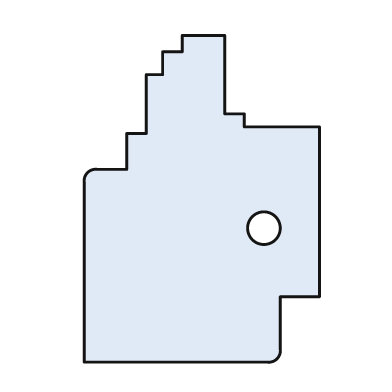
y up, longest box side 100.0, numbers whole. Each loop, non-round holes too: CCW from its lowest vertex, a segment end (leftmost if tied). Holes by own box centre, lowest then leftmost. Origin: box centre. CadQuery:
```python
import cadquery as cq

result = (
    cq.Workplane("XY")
    .moveTo(-36.0, -50.0)
    .lineTo(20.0, -50.0)
    .threePointArc((23.0, -49.0), (24.0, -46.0))
    .lineTo(24.0, -30.0)
    .lineTo(36.0, -30.0)
    .lineTo(36.0, 22.0)
    .lineTo(13.0, 22.0)
    .lineTo(13.0, 26.0)
    .lineTo(7.0, 26.0)
    .lineTo(7.0, 50.0)
    .lineTo(-6.0, 50.0)
    .lineTo(-6.0, 45.0)
    .lineTo(-12.0, 45.0)
    .lineTo(-12.0, 38.0)
    .lineTo(-17.0, 38.0)
    .lineTo(-17.0, 20.0)
    .lineTo(-23.0, 20.0)
    .lineTo(-23.0, 9.0)
    .lineTo(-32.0, 9.0)
    .threePointArc((-35.0, 8.0), (-36.0, 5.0))
    .close()
    .moveTo(19.0, -9.0)
    .circle(5.0)
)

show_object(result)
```